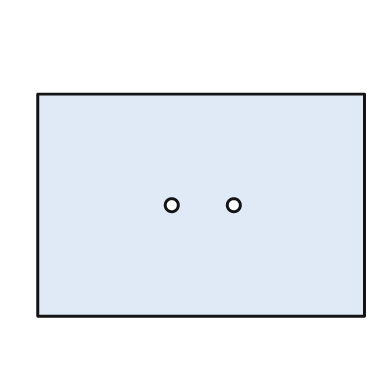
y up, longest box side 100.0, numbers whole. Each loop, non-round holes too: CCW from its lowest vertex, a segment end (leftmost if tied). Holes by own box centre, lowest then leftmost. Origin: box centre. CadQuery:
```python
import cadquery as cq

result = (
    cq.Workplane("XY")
    .moveTo(-50.0, -34.0)
    .lineTo(50.0, -34.0)
    .lineTo(50.0, 34.0)
    .lineTo(-50.0, 34.0)
    .close()
    .moveTo(-9.0, 0.0)
    .circle(2.0)
    .moveTo(10.0, 0.0)
    .circle(2.0)
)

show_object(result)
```